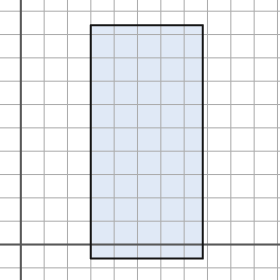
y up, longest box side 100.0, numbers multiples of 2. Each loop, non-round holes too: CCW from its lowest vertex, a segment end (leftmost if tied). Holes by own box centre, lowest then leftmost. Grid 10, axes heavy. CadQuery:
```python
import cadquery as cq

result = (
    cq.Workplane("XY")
    .moveTo(30.0, -6.0)
    .lineTo(78.0, -6.0)
    .lineTo(78.0, 94.0)
    .lineTo(30.0, 94.0)
    .close()
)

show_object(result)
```